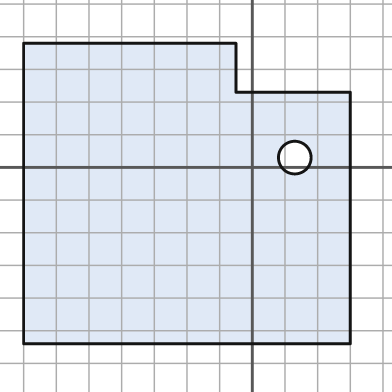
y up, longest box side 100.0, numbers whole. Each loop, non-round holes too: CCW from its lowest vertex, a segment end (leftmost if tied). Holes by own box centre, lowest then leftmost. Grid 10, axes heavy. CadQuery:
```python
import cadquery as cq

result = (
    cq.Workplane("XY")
    .moveTo(-70.0, -54.0)
    .lineTo(30.0, -54.0)
    .lineTo(30.0, 23.0)
    .lineTo(-5.0, 23.0)
    .lineTo(-5.0, 38.0)
    .lineTo(-70.0, 38.0)
    .close()
    .moveTo(13.0, 3.0)
    .circle(5.0)
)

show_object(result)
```